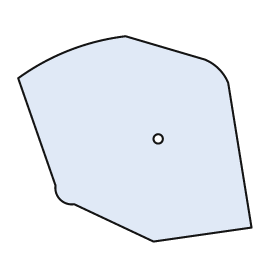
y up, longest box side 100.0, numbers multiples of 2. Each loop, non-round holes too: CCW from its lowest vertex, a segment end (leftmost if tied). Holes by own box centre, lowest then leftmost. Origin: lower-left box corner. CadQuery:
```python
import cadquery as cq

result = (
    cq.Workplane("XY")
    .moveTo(58.0, 0.0)
    .lineTo(100.0, 6.0)
    .lineTo(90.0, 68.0)
    .threePointArc((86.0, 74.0), (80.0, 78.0))
    .lineTo(46.0, 88.0)
    .threePointArc((22.0, 82.0), (0.0, 70.0))
    .lineTo(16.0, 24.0)
    .threePointArc((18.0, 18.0), (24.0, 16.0))
    .close()
    .moveTo(60.0, 44.0)
    .circle(2.0)
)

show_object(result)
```